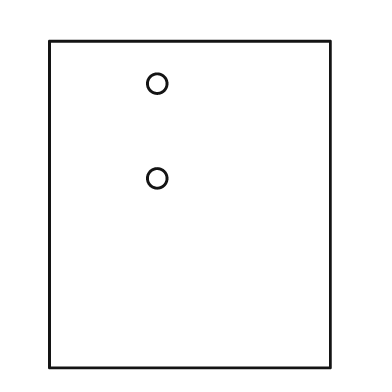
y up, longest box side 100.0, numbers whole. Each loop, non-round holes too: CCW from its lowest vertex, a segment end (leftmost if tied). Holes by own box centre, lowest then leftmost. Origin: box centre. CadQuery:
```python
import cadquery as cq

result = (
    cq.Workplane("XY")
    .moveTo(-43.0, -50.0)
    .lineTo(43.0, -50.0)
    .lineTo(43.0, 50.0)
    .lineTo(-43.0, 50.0)
    .close()
    .moveTo(-10.0, 8.0)
    .circle(3.0)
    .moveTo(-10.0, 37.0)
    .circle(3.0)
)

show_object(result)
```